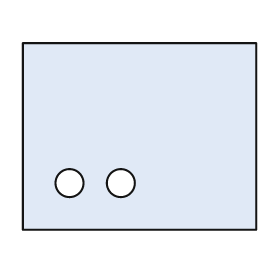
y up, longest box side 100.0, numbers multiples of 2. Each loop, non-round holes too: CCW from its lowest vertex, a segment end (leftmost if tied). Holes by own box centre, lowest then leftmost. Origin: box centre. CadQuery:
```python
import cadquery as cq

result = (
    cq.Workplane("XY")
    .moveTo(-50.0, -40.0)
    .lineTo(50.0, -40.0)
    .lineTo(50.0, 40.0)
    .lineTo(-50.0, 40.0)
    .close()
    .moveTo(-30.0, -20.0)
    .circle(6.0)
    .moveTo(-8.0, -20.0)
    .circle(6.0)
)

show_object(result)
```